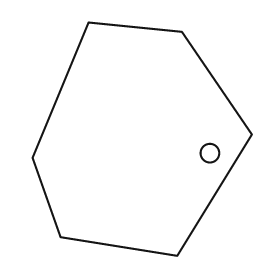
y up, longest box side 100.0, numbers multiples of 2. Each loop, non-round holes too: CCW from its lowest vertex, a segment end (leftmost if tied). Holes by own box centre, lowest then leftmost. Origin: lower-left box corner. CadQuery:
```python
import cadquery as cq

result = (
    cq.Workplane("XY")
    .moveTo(62.0, 0.0)
    .lineTo(94.0, 52.0)
    .lineTo(64.0, 96.0)
    .lineTo(24.0, 100.0)
    .lineTo(0.0, 42.0)
    .lineTo(12.0, 8.0)
    .close()
    .moveTo(76.0, 44.0)
    .circle(4.0)
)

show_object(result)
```